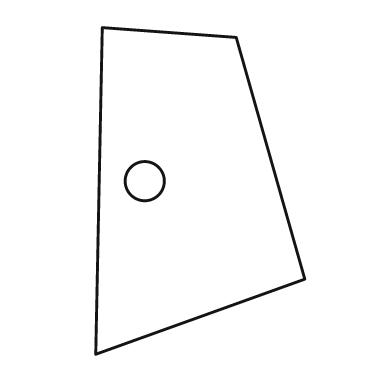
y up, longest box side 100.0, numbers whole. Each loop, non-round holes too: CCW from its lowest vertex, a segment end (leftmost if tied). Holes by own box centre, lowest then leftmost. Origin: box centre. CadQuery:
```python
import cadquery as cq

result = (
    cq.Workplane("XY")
    .moveTo(-32.0, -50.0)
    .lineTo(32.0, -27.0)
    .lineTo(11.0, 47.0)
    .lineTo(-30.0, 50.0)
    .close()
    .moveTo(-17.0, 3.0)
    .circle(6.0)
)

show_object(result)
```